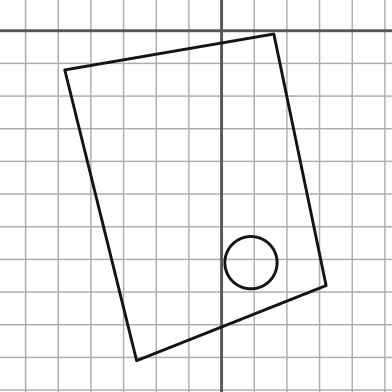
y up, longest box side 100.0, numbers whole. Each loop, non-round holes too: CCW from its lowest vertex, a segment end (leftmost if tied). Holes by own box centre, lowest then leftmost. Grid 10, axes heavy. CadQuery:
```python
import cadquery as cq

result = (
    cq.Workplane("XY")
    .moveTo(-26.0, -101.0)
    .lineTo(32.0, -78.0)
    .lineTo(16.0, -1.0)
    .lineTo(-48.0, -12.0)
    .close()
    .moveTo(9.0, -71.0)
    .circle(8.0)
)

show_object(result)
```